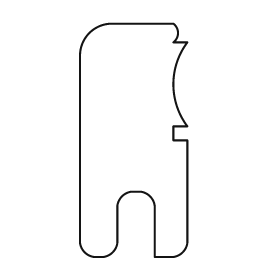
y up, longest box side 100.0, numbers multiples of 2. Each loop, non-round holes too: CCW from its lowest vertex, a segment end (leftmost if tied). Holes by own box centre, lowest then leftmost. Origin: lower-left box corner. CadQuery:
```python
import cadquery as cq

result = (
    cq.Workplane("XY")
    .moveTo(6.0, 0.0)
    .lineTo(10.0, 0.0)
    .threePointArc((14.0, 2.0), (16.0, 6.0))
    .lineTo(16.0, 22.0)
    .threePointArc((18.0, 26.0), (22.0, 28.0))
    .lineTo(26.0, 28.0)
    .threePointArc((30.0, 26.0), (32.0, 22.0))
    .lineTo(32.0, 0.0)
    .lineTo(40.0, 0.0)
    .threePointArc((44.0, 2.0), (46.0, 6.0))
    .lineTo(46.0, 50.0)
    .lineTo(40.0, 50.0)
    .lineTo(40.0, 56.0)
    .lineTo(46.0, 56.0)
    .threePointArc((40.0, 74.0), (46.0, 92.0))
    .lineTo(40.0, 92.0)
    .threePointArc((42.0, 96.0), (40.0, 100.0))
    .lineTo(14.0, 100.0)
    .threePointArc((4.0, 96.0), (0.0, 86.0))
    .lineTo(0.0, 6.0)
    .threePointArc((2.0, 2.0), (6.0, 0.0))
    .close()
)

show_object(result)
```